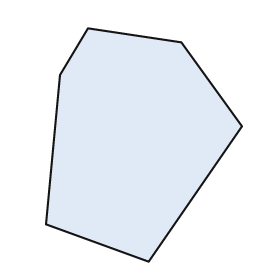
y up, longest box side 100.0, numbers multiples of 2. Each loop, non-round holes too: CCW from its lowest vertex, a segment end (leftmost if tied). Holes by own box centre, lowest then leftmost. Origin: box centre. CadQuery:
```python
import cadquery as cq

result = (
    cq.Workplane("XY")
    .moveTo(2.0, -50.0)
    .lineTo(42.0, 8.0)
    .lineTo(16.0, 44.0)
    .lineTo(-24.0, 50.0)
    .lineTo(-36.0, 30.0)
    .lineTo(-42.0, -34.0)
    .close()
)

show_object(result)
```